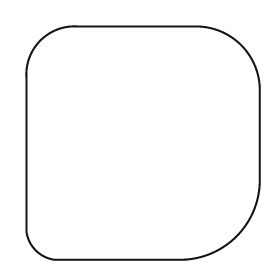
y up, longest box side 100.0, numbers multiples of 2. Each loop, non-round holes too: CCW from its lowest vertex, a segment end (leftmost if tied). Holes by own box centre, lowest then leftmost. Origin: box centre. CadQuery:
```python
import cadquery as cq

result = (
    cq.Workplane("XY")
    .moveTo(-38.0, -50.0)
    .lineTo(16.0, -50.0)
    .threePointArc((40.0, -40.0), (50.0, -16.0))
    .lineTo(50.0, 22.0)
    .threePointArc((42.0, 42.0), (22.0, 50.0))
    .lineTo(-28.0, 50.0)
    .threePointArc((-44.0, 44.0), (-50.0, 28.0))
    .lineTo(-50.0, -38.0)
    .threePointArc((-46.0, -46.0), (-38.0, -50.0))
    .close()
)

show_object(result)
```